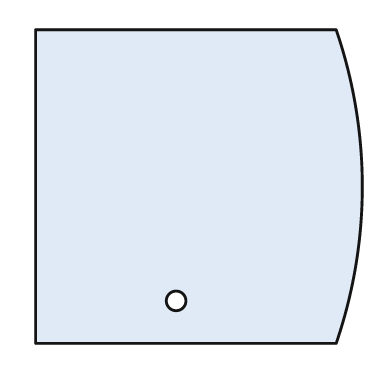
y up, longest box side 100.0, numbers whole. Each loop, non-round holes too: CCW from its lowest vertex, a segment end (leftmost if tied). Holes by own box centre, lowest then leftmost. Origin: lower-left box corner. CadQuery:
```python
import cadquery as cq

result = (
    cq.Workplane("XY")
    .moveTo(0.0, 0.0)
    .lineTo(92.0, 0.0)
    .threePointArc((100.0, 48.0), (92.0, 96.0))
    .lineTo(0.0, 96.0)
    .close()
    .moveTo(43.0, 13.0)
    .circle(3.0)
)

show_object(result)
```